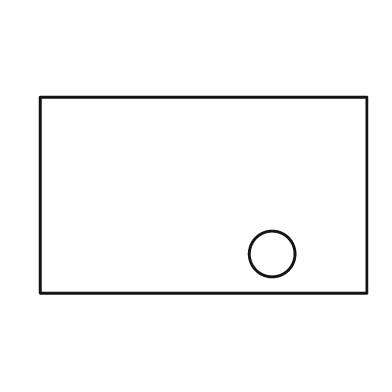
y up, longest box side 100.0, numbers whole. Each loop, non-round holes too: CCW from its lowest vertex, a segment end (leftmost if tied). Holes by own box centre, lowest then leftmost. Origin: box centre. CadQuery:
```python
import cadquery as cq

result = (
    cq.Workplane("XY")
    .moveTo(-50.0, -30.0)
    .lineTo(50.0, -30.0)
    .lineTo(50.0, 30.0)
    .lineTo(-50.0, 30.0)
    .close()
    .moveTo(21.0, -18.0)
    .circle(7.0)
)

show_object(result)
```